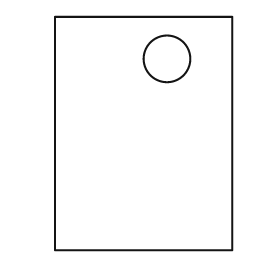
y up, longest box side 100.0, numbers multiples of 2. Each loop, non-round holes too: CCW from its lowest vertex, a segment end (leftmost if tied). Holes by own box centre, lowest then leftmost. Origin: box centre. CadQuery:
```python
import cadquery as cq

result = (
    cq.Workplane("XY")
    .moveTo(-38.0, -50.0)
    .lineTo(38.0, -50.0)
    .lineTo(38.0, 50.0)
    .lineTo(-38.0, 50.0)
    .close()
    .moveTo(10.0, 32.0)
    .circle(10.0)
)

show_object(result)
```